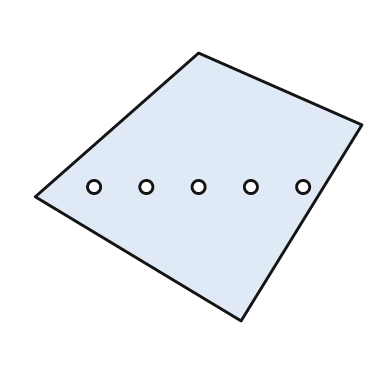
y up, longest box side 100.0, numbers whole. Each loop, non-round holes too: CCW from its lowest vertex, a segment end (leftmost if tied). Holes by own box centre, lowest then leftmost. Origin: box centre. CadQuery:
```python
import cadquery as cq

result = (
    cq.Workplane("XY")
    .moveTo(13.0, -41.0)
    .lineTo(50.0, 19.0)
    .lineTo(0.0, 41.0)
    .lineTo(-50.0, -3.0)
    .close()
    .moveTo(-32.0, 0.0)
    .circle(2.0)
    .moveTo(-16.0, 0.0)
    .circle(2.0)
    .moveTo(0.0, 0.0)
    .circle(2.0)
    .moveTo(16.0, 0.0)
    .circle(2.0)
    .moveTo(32.0, 0.0)
    .circle(2.0)
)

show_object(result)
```